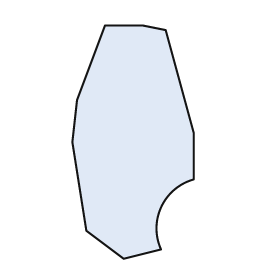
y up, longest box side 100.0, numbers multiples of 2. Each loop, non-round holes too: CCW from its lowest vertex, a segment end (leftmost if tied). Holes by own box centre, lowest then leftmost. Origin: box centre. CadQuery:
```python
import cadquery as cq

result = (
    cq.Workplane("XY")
    .moveTo(-4.0, -50.0)
    .lineTo(12.0, -46.0)
    .threePointArc((12.0, -28.0), (26.0, -16.0))
    .lineTo(26.0, 4.0)
    .lineTo(14.0, 48.0)
    .lineTo(4.0, 50.0)
    .lineTo(-12.0, 50.0)
    .lineTo(-24.0, 18.0)
    .lineTo(-26.0, 0.0)
    .lineTo(-20.0, -38.0)
    .close()
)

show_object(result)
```